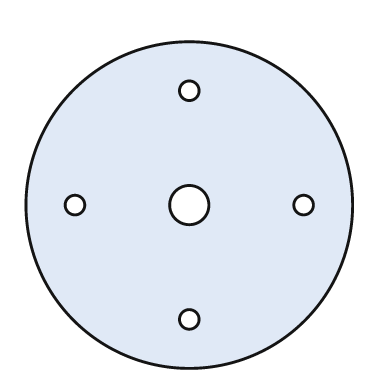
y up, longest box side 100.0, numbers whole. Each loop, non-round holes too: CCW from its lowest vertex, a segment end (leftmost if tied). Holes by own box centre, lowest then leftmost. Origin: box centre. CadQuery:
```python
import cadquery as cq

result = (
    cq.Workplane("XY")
    .moveTo(0.0, 0.0)
    .circle(50.0)
    .moveTo(0.0, -35.0)
    .circle(3.0)
    .moveTo(-35.0, 0.0)
    .circle(3.0)
    .moveTo(0.0, 0.0)
    .circle(6.0)
    .moveTo(35.0, 0.0)
    .circle(3.0)
    .moveTo(0.0, 35.0)
    .circle(3.0)
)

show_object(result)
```